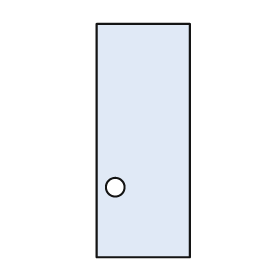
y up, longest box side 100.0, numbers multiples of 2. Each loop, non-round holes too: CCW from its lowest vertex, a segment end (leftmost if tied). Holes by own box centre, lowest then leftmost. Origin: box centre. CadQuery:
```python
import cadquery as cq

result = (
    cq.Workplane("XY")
    .moveTo(-20.0, -50.0)
    .lineTo(20.0, -50.0)
    .lineTo(20.0, 50.0)
    .lineTo(-20.0, 50.0)
    .close()
    .moveTo(-12.0, -20.0)
    .circle(4.0)
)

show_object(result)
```